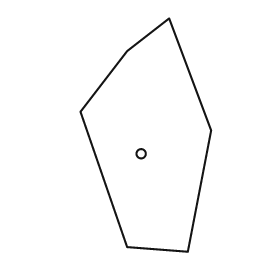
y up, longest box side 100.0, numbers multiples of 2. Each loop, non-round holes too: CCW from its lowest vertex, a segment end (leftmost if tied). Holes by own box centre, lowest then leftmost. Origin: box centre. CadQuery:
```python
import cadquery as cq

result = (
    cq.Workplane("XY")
    .moveTo(18.0, -50.0)
    .lineTo(28.0, 2.0)
    .lineTo(10.0, 50.0)
    .lineTo(-8.0, 36.0)
    .lineTo(-28.0, 10.0)
    .lineTo(-8.0, -48.0)
    .close()
    .moveTo(-2.0, -8.0)
    .circle(2.0)
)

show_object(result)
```